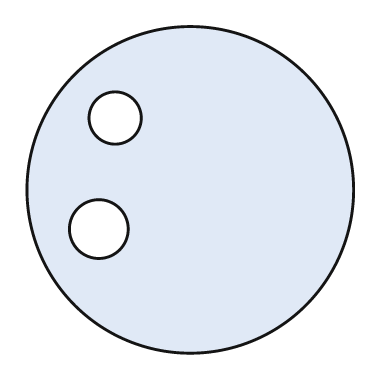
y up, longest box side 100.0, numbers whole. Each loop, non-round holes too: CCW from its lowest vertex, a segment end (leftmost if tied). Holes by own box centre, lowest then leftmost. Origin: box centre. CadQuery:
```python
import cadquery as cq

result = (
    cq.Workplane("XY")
    .moveTo(0.0, 0.0)
    .circle(50.0)
    .moveTo(-28.0, -12.0)
    .circle(9.0)
    .moveTo(-23.0, 22.0)
    .circle(8.0)
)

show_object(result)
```